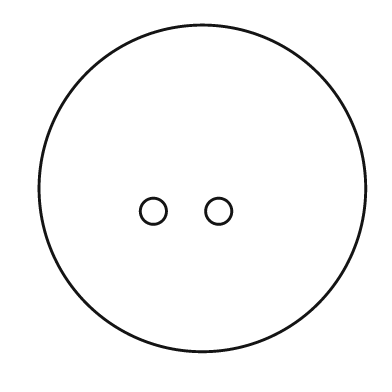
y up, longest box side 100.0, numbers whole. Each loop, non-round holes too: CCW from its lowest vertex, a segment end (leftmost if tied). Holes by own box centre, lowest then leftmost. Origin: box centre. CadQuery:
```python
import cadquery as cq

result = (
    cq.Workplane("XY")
    .moveTo(0.0, 0.0)
    .circle(50.0)
    .moveTo(-15.0, -7.0)
    .circle(4.0)
    .moveTo(5.0, -7.0)
    .circle(4.0)
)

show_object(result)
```